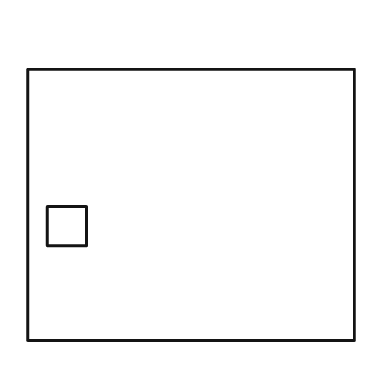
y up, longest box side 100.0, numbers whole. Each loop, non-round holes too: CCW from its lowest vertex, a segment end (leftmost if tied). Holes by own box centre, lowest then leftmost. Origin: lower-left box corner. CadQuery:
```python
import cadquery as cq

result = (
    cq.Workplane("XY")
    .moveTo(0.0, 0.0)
    .lineTo(100.0, 0.0)
    .lineTo(100.0, 83.0)
    .lineTo(0.0, 83.0)
    .close()
    .moveTo(6.0, 29.0)
    .lineTo(18.0, 29.0)
    .lineTo(18.0, 41.0)
    .lineTo(6.0, 41.0)
    .close()
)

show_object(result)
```